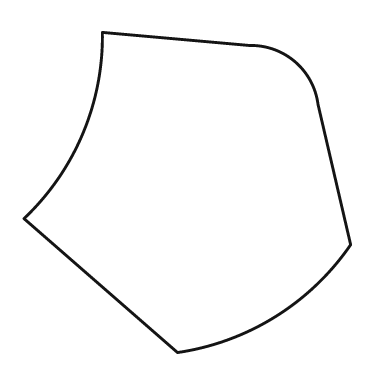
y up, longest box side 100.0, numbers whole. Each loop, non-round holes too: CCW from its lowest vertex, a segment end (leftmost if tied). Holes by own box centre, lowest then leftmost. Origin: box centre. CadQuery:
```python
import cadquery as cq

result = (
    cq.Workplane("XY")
    .moveTo(-3.0, -49.0)
    .threePointArc((27.0, -38.0), (50.0, -16.0))
    .lineTo(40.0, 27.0)
    .threePointArc((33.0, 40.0), (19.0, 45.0))
    .lineTo(-26.0, 49.0)
    .threePointArc((-32.0, 18.0), (-50.0, -8.0))
    .close()
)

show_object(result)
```